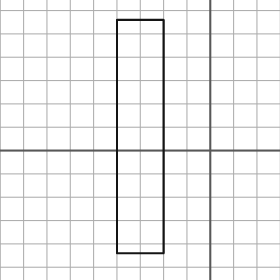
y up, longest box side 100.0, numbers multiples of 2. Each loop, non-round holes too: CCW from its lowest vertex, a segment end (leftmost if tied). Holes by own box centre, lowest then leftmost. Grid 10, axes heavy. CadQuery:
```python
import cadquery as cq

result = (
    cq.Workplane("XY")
    .moveTo(-40.0, -44.0)
    .lineTo(-20.0, -44.0)
    .lineTo(-20.0, 56.0)
    .lineTo(-40.0, 56.0)
    .close()
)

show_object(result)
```